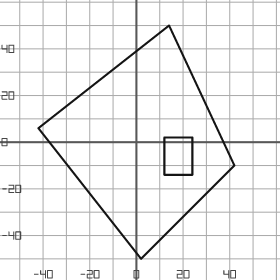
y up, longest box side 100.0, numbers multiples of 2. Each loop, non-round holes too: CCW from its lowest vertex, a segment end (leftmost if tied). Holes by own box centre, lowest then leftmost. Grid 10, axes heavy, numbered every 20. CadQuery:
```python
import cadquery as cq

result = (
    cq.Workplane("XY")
    .moveTo(2.0, -50.0)
    .lineTo(42.0, -10.0)
    .lineTo(14.0, 50.0)
    .lineTo(-42.0, 6.0)
    .close()
    .moveTo(12.0, -14.0)
    .lineTo(24.0, -14.0)
    .lineTo(24.0, 2.0)
    .lineTo(12.0, 2.0)
    .close()
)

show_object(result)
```